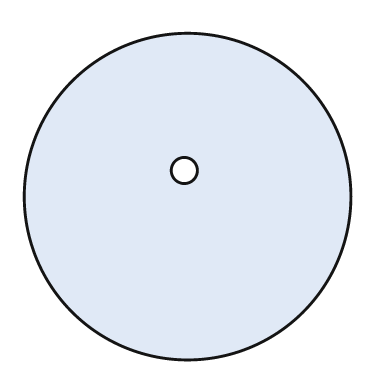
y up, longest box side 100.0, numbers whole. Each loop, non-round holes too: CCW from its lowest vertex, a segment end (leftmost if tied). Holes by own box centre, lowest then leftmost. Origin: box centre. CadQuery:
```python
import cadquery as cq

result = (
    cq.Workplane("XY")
    .moveTo(0.0, 0.0)
    .circle(50.0)
    .moveTo(-1.0, 8.0)
    .circle(4.0)
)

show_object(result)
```